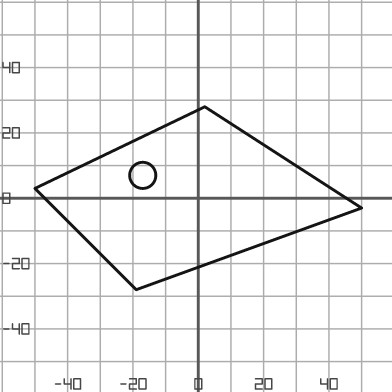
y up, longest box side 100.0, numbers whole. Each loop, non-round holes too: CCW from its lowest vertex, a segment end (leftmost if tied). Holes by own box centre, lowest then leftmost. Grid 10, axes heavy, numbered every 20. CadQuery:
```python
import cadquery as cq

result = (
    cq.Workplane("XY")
    .moveTo(-19.0, -28.0)
    .lineTo(50.0, -3.0)
    .lineTo(2.0, 28.0)
    .lineTo(-50.0, 3.0)
    .close()
    .moveTo(-17.0, 7.0)
    .circle(4.0)
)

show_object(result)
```